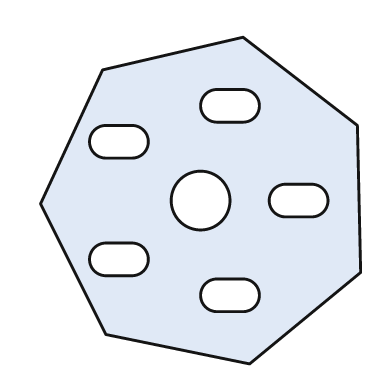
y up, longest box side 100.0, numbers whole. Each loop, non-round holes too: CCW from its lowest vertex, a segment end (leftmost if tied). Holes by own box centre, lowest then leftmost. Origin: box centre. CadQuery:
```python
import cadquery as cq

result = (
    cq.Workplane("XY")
    .moveTo(15.0, -50.0)
    .lineTo(49.0, -22.0)
    .lineTo(48.0, 23.0)
    .lineTo(13.0, 50.0)
    .lineTo(-30.0, 40.0)
    .lineTo(-49.0, -1.0)
    .lineTo(-29.0, -41.0)
    .close()
    .moveTo(5.0, -34.0)
    .lineTo(13.0, -34.0)
    .threePointArc((18.0, -29.0), (13.0, -24.0))
    .lineTo(5.0, -24.0)
    .threePointArc((0.0, -29.0), (5.0, -34.0))
    .close()
    .moveTo(-29.0, -23.0)
    .lineTo(-21.0, -23.0)
    .threePointArc((-16.0, -18.0), (-21.0, -13.0))
    .lineTo(-29.0, -13.0)
    .threePointArc((-34.0, -18.0), (-29.0, -23.0))
    .close()
    .moveTo(0.0, 0.0)
    .circle(9.0)
    .moveTo(26.0, -5.0)
    .lineTo(34.0, -5.0)
    .threePointArc((39.0, 0.0), (34.0, 5.0))
    .lineTo(26.0, 5.0)
    .threePointArc((21.0, 0.0), (26.0, -5.0))
    .close()
    .moveTo(-29.0, 13.0)
    .lineTo(-21.0, 13.0)
    .threePointArc((-16.0, 18.0), (-21.0, 23.0))
    .lineTo(-29.0, 23.0)
    .threePointArc((-34.0, 18.0), (-29.0, 13.0))
    .close()
    .moveTo(5.0, 24.0)
    .lineTo(13.0, 24.0)
    .threePointArc((18.0, 29.0), (13.0, 34.0))
    .lineTo(5.0, 34.0)
    .threePointArc((0.0, 29.0), (5.0, 24.0))
    .close()
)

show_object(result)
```